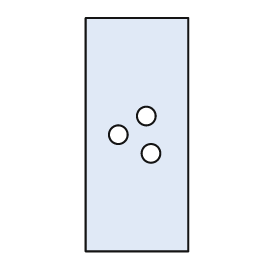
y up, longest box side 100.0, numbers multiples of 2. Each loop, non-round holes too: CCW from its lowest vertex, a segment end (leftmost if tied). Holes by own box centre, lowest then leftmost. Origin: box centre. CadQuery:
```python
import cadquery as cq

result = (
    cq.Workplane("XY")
    .moveTo(-22.0, -50.0)
    .lineTo(22.0, -50.0)
    .lineTo(22.0, 50.0)
    .lineTo(-22.0, 50.0)
    .close()
    .moveTo(6.0, -8.0)
    .circle(4.0)
    .moveTo(-8.0, 0.0)
    .circle(4.0)
    .moveTo(4.0, 8.0)
    .circle(4.0)
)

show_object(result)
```